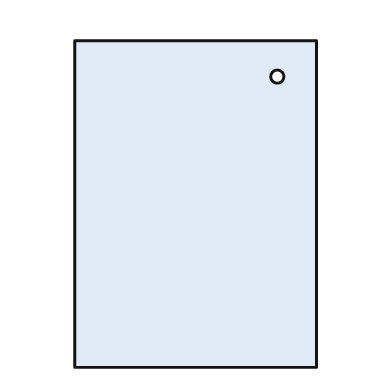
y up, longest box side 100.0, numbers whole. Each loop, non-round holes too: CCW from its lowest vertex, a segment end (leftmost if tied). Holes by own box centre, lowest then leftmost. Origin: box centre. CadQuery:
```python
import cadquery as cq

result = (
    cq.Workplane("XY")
    .moveTo(-37.0, -50.0)
    .lineTo(37.0, -50.0)
    .lineTo(37.0, 50.0)
    .lineTo(-37.0, 50.0)
    .close()
    .moveTo(25.0, 39.0)
    .circle(2.0)
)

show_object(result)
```